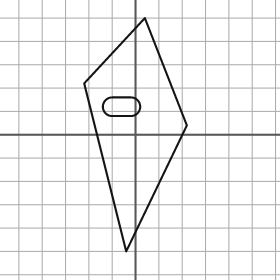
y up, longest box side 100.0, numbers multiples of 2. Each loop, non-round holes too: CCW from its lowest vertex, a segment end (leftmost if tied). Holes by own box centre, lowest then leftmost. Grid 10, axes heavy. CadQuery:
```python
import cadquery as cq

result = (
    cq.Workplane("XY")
    .moveTo(-4.0, -50.0)
    .lineTo(22.0, 4.0)
    .lineTo(4.0, 50.0)
    .lineTo(-22.0, 22.0)
    .close()
    .moveTo(-10.0, 8.0)
    .lineTo(-2.0, 8.0)
    .threePointArc((2.0, 12.0), (-2.0, 16.0))
    .lineTo(-10.0, 16.0)
    .threePointArc((-14.0, 12.0), (-10.0, 8.0))
    .close()
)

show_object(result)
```